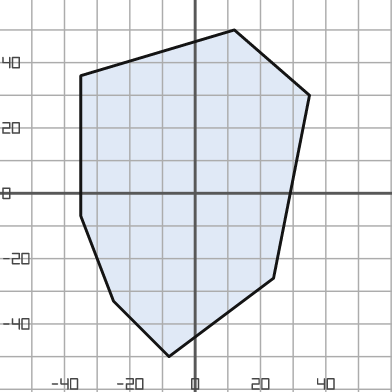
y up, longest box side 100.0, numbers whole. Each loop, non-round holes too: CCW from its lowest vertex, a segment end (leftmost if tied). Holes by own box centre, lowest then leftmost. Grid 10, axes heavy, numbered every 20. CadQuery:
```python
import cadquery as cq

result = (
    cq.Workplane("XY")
    .moveTo(-8.0, -50.0)
    .lineTo(24.0, -26.0)
    .lineTo(35.0, 30.0)
    .lineTo(12.0, 50.0)
    .lineTo(-35.0, 36.0)
    .lineTo(-35.0, -7.0)
    .lineTo(-25.0, -33.0)
    .close()
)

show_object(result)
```